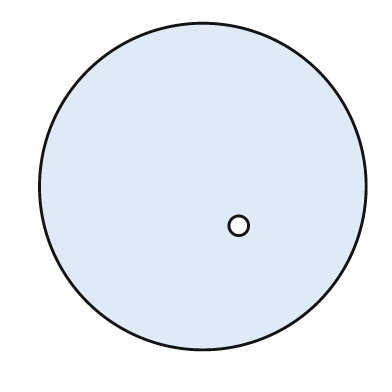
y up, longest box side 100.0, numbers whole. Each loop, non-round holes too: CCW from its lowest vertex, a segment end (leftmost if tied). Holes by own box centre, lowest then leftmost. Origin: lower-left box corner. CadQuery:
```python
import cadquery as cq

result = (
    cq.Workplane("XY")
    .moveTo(50.0, 50.0)
    .circle(50.0)
    .moveTo(61.0, 38.0)
    .circle(3.0)
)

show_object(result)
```